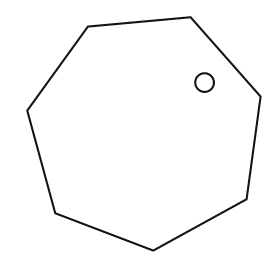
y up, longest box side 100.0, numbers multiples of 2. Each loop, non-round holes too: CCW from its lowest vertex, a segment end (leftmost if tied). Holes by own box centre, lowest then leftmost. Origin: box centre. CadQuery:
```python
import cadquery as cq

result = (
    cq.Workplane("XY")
    .moveTo(4.0, -50.0)
    .lineTo(44.0, -28.0)
    .lineTo(50.0, 16.0)
    .lineTo(20.0, 50.0)
    .lineTo(-24.0, 46.0)
    .lineTo(-50.0, 10.0)
    .lineTo(-38.0, -34.0)
    .close()
    .moveTo(26.0, 22.0)
    .circle(4.0)
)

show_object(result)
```